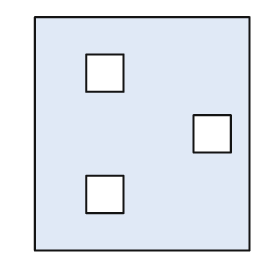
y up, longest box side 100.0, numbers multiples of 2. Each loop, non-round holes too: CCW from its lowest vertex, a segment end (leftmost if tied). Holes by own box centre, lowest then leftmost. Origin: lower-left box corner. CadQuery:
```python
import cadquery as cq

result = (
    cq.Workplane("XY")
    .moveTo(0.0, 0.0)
    .lineTo(92.0, 0.0)
    .lineTo(92.0, 100.0)
    .lineTo(0.0, 100.0)
    .close()
    .moveTo(22.0, 16.0)
    .lineTo(38.0, 16.0)
    .lineTo(38.0, 32.0)
    .lineTo(22.0, 32.0)
    .close()
    .moveTo(68.0, 42.0)
    .lineTo(84.0, 42.0)
    .lineTo(84.0, 58.0)
    .lineTo(68.0, 58.0)
    .close()
    .moveTo(22.0, 68.0)
    .lineTo(38.0, 68.0)
    .lineTo(38.0, 84.0)
    .lineTo(22.0, 84.0)
    .close()
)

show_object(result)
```